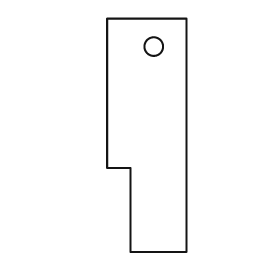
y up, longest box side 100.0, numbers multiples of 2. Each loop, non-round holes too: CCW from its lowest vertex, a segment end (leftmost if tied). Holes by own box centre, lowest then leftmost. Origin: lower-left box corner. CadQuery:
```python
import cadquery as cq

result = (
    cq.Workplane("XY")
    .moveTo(10.0, 0.0)
    .lineTo(34.0, 0.0)
    .lineTo(34.0, 100.0)
    .lineTo(0.0, 100.0)
    .lineTo(0.0, 36.0)
    .lineTo(10.0, 36.0)
    .close()
    .moveTo(20.0, 88.0)
    .circle(4.0)
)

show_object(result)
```